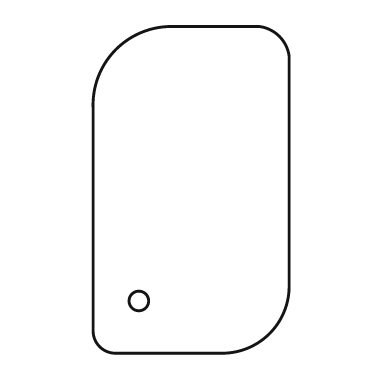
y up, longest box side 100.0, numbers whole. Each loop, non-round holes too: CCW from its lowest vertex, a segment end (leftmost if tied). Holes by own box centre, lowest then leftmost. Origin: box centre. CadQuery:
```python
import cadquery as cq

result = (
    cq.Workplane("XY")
    .moveTo(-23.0, -50.0)
    .lineTo(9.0, -50.0)
    .threePointArc((24.0, -44.0), (30.0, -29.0))
    .lineTo(30.0, 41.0)
    .threePointArc((27.0, 47.0), (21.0, 50.0))
    .lineTo(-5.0, 50.0)
    .threePointArc((-23.0, 43.0), (-30.0, 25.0))
    .lineTo(-30.0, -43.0)
    .threePointArc((-28.0, -48.0), (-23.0, -50.0))
    .close()
    .moveTo(-16.0, -34.0)
    .circle(3.0)
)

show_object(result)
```